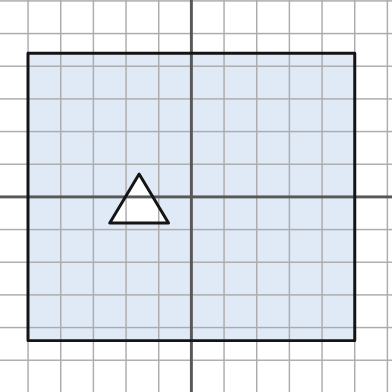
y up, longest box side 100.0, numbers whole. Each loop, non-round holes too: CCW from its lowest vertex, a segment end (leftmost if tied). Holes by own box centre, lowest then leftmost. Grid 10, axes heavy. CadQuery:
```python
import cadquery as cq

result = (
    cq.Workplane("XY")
    .moveTo(-50.0, -44.0)
    .lineTo(50.0, -44.0)
    .lineTo(50.0, 44.0)
    .lineTo(-50.0, 44.0)
    .close()
    .moveTo(-25.0, -8.0)
    .lineTo(-7.0, -8.0)
    .lineTo(-16.0, 7.0)
    .close()
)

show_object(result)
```